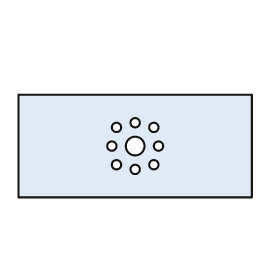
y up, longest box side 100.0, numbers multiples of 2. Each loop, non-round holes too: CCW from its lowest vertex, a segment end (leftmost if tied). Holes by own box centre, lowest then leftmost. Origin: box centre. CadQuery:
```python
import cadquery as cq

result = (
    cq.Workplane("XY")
    .moveTo(-50.0, -22.0)
    .lineTo(50.0, -22.0)
    .lineTo(50.0, 22.0)
    .lineTo(-50.0, 22.0)
    .close()
    .moveTo(0.0, -10.0)
    .circle(2.0)
    .moveTo(-8.0, -8.0)
    .circle(2.0)
    .moveTo(8.0, -8.0)
    .circle(2.0)
    .moveTo(-10.0, 0.0)
    .circle(2.0)
    .moveTo(0.0, 0.0)
    .circle(4.0)
    .moveTo(10.0, 0.0)
    .circle(2.0)
    .moveTo(-8.0, 8.0)
    .circle(2.0)
    .moveTo(8.0, 8.0)
    .circle(2.0)
    .moveTo(0.0, 10.0)
    .circle(2.0)
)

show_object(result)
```